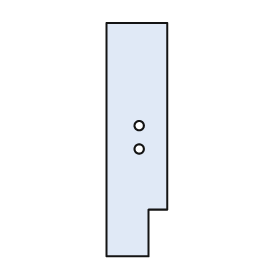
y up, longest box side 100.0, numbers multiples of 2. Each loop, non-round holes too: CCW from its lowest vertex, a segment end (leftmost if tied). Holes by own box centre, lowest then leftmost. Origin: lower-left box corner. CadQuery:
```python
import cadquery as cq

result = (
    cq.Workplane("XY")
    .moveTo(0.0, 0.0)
    .lineTo(18.0, 0.0)
    .lineTo(18.0, 20.0)
    .lineTo(26.0, 20.0)
    .lineTo(26.0, 100.0)
    .lineTo(0.0, 100.0)
    .close()
    .moveTo(14.0, 46.0)
    .circle(2.0)
    .moveTo(14.0, 56.0)
    .circle(2.0)
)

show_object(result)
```